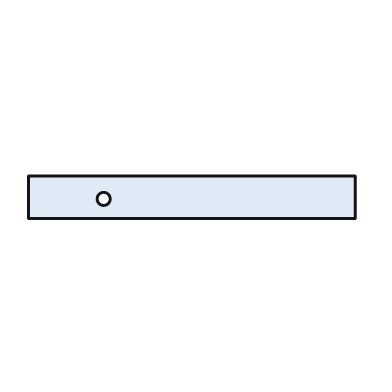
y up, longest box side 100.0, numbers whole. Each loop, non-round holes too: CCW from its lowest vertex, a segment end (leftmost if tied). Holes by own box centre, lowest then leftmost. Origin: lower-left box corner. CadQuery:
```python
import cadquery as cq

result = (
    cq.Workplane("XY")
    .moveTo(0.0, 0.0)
    .lineTo(100.0, 0.0)
    .lineTo(100.0, 13.0)
    .lineTo(0.0, 13.0)
    .close()
    .moveTo(23.0, 6.0)
    .circle(2.0)
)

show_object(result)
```